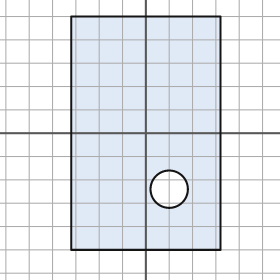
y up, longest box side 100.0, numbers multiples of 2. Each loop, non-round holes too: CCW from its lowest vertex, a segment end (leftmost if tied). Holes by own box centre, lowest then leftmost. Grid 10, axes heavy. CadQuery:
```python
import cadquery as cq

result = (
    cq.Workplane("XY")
    .moveTo(-32.0, -50.0)
    .lineTo(32.0, -50.0)
    .lineTo(32.0, 50.0)
    .lineTo(-32.0, 50.0)
    .close()
    .moveTo(10.0, -24.0)
    .circle(8.0)
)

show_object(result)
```